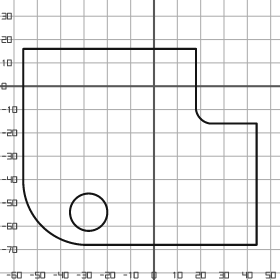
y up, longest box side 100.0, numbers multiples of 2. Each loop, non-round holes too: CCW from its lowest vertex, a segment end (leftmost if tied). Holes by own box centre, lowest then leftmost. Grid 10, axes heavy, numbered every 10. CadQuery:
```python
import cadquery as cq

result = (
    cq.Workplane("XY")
    .moveTo(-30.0, -68.0)
    .lineTo(44.0, -68.0)
    .lineTo(44.0, -16.0)
    .lineTo(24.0, -16.0)
    .threePointArc((20.0, -14.0), (18.0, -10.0))
    .lineTo(18.0, 16.0)
    .lineTo(-56.0, 16.0)
    .lineTo(-56.0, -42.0)
    .threePointArc((-48.0, -60.0), (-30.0, -68.0))
    .close()
    .moveTo(-28.0, -54.0)
    .circle(8.0)
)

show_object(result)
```